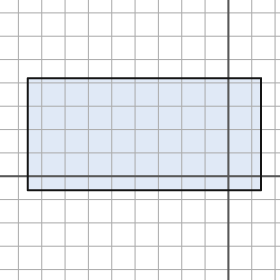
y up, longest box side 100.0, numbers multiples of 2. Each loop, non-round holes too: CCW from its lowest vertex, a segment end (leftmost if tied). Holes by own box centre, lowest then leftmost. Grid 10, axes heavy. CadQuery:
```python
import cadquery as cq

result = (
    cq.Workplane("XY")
    .moveTo(-86.0, -6.0)
    .lineTo(14.0, -6.0)
    .lineTo(14.0, 42.0)
    .lineTo(-86.0, 42.0)
    .close()
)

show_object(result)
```